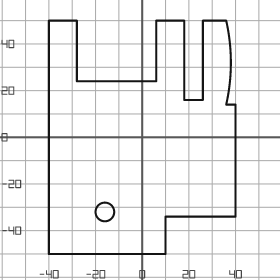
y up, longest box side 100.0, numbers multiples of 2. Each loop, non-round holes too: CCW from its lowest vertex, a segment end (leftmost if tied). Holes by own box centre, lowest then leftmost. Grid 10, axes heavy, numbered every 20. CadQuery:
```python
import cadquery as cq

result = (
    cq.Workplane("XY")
    .moveTo(-40.0, -50.0)
    .lineTo(10.0, -50.0)
    .lineTo(10.0, -34.0)
    .lineTo(40.0, -34.0)
    .lineTo(40.0, 14.0)
    .lineTo(36.0, 14.0)
    .threePointArc((38.0, 32.0), (36.0, 50.0))
    .lineTo(26.0, 50.0)
    .lineTo(26.0, 16.0)
    .lineTo(18.0, 16.0)
    .lineTo(18.0, 50.0)
    .lineTo(6.0, 50.0)
    .lineTo(6.0, 24.0)
    .lineTo(-28.0, 24.0)
    .lineTo(-28.0, 50.0)
    .lineTo(-40.0, 50.0)
    .close()
    .moveTo(-16.0, -32.0)
    .circle(4.0)
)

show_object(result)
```